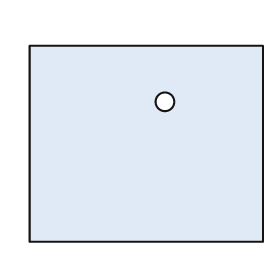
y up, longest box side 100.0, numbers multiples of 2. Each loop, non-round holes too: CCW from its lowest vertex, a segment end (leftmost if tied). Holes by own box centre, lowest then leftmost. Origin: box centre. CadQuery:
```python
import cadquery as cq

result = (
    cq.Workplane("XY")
    .moveTo(-50.0, -42.0)
    .lineTo(50.0, -42.0)
    .lineTo(50.0, 42.0)
    .lineTo(-50.0, 42.0)
    .close()
    .moveTo(8.0, 18.0)
    .circle(4.0)
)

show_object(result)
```